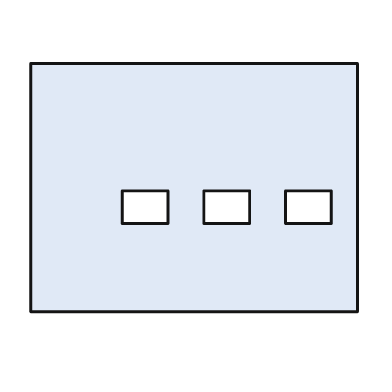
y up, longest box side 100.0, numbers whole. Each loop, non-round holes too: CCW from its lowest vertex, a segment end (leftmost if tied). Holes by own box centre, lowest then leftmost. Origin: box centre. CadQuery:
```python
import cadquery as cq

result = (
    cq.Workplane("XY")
    .moveTo(-50.0, -38.0)
    .lineTo(50.0, -38.0)
    .lineTo(50.0, 38.0)
    .lineTo(-50.0, 38.0)
    .close()
    .moveTo(-22.0, -11.0)
    .lineTo(-8.0, -11.0)
    .lineTo(-8.0, -1.0)
    .lineTo(-22.0, -1.0)
    .close()
    .moveTo(3.0, -11.0)
    .lineTo(17.0, -11.0)
    .lineTo(17.0, -1.0)
    .lineTo(3.0, -1.0)
    .close()
    .moveTo(28.0, -11.0)
    .lineTo(42.0, -11.0)
    .lineTo(42.0, -1.0)
    .lineTo(28.0, -1.0)
    .close()
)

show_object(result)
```